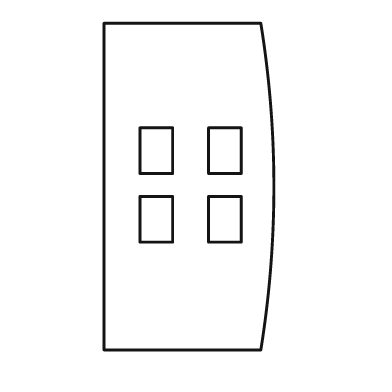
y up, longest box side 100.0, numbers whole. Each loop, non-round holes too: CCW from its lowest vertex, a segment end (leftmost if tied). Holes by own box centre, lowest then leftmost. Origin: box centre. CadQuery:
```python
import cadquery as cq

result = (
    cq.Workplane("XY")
    .moveTo(-26.0, -50.0)
    .lineTo(22.0, -50.0)
    .threePointArc((26.0, 0.0), (22.0, 50.0))
    .lineTo(-26.0, 50.0)
    .close()
    .moveTo(-15.0, -17.0)
    .lineTo(-5.0, -17.0)
    .lineTo(-5.0, -3.0)
    .lineTo(-15.0, -3.0)
    .close()
    .moveTo(6.0, -17.0)
    .lineTo(16.0, -17.0)
    .lineTo(16.0, -3.0)
    .lineTo(6.0, -3.0)
    .close()
    .moveTo(-15.0, 4.0)
    .lineTo(-5.0, 4.0)
    .lineTo(-5.0, 18.0)
    .lineTo(-15.0, 18.0)
    .close()
    .moveTo(6.0, 4.0)
    .lineTo(16.0, 4.0)
    .lineTo(16.0, 18.0)
    .lineTo(6.0, 18.0)
    .close()
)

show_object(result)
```